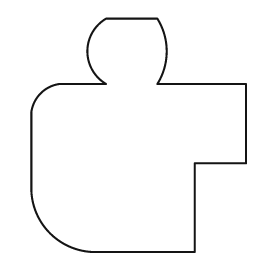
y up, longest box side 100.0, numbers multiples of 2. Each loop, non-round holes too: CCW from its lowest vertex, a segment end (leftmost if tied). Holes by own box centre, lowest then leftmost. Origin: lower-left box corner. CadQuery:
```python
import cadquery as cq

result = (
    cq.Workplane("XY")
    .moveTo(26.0, 0.0)
    .lineTo(70.0, 0.0)
    .lineTo(70.0, 38.0)
    .lineTo(92.0, 38.0)
    .lineTo(92.0, 72.0)
    .lineTo(54.0, 72.0)
    .threePointArc((58.0, 86.0), (54.0, 100.0))
    .lineTo(32.0, 100.0)
    .threePointArc((24.0, 86.0), (32.0, 72.0))
    .lineTo(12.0, 72.0)
    .threePointArc((4.0, 68.0), (0.0, 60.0))
    .lineTo(0.0, 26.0)
    .threePointArc((8.0, 8.0), (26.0, 0.0))
    .close()
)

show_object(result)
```